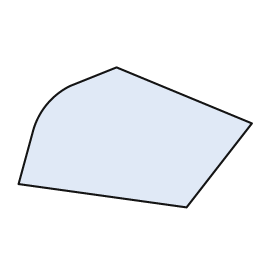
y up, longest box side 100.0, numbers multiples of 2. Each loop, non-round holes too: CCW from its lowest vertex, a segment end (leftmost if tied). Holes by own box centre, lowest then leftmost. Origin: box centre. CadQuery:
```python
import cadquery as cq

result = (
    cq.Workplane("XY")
    .moveTo(22.0, -30.0)
    .lineTo(50.0, 6.0)
    .lineTo(-8.0, 30.0)
    .lineTo(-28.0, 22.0)
    .threePointArc((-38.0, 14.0), (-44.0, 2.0))
    .lineTo(-50.0, -20.0)
    .close()
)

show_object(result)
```